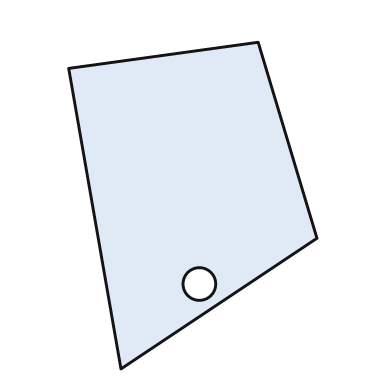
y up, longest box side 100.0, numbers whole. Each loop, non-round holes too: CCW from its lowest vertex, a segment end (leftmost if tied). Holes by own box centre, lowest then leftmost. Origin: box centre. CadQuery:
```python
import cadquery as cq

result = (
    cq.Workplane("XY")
    .moveTo(-22.0, -50.0)
    .lineTo(38.0, -10.0)
    .lineTo(20.0, 50.0)
    .lineTo(-38.0, 42.0)
    .close()
    .moveTo(2.0, -24.0)
    .circle(5.0)
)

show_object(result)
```